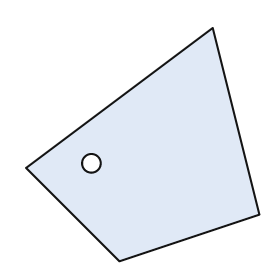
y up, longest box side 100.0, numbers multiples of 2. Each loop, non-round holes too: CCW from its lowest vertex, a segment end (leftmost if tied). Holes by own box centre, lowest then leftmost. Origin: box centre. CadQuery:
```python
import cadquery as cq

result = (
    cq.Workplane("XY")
    .moveTo(-10.0, -50.0)
    .lineTo(50.0, -30.0)
    .lineTo(30.0, 50.0)
    .lineTo(-50.0, -10.0)
    .close()
    .moveTo(-22.0, -8.0)
    .circle(4.0)
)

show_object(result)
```